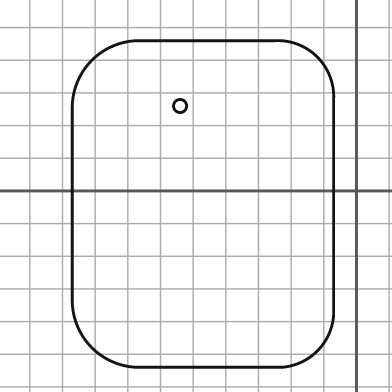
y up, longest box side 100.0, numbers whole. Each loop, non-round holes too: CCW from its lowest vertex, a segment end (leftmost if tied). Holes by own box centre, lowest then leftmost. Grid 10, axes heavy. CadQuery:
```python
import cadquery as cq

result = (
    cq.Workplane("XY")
    .moveTo(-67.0, -54.0)
    .lineTo(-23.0, -54.0)
    .threePointArc((-12.0, -49.0), (-7.0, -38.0))
    .lineTo(-7.0, 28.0)
    .threePointArc((-12.0, 41.0), (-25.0, 46.0))
    .lineTo(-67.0, 46.0)
    .threePointArc((-81.0, 40.0), (-87.0, 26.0))
    .lineTo(-87.0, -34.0)
    .threePointArc((-81.0, -48.0), (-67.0, -54.0))
    .close()
    .moveTo(-54.0, 26.0)
    .circle(2.0)
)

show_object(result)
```